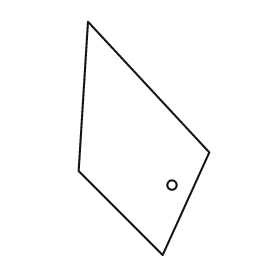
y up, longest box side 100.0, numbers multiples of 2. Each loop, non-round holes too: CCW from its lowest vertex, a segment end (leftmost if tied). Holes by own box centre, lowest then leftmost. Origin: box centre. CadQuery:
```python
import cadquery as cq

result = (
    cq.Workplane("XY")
    .moveTo(8.0, -50.0)
    .lineTo(28.0, -6.0)
    .lineTo(-24.0, 50.0)
    .lineTo(-28.0, -14.0)
    .close()
    .moveTo(12.0, -20.0)
    .circle(2.0)
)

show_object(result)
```